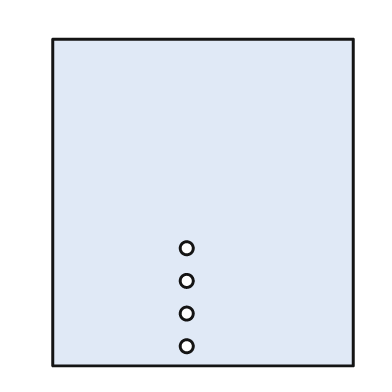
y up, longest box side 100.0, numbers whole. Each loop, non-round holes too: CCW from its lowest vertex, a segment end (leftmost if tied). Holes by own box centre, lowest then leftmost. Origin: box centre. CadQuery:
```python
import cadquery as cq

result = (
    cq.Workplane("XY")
    .moveTo(-46.0, -50.0)
    .lineTo(46.0, -50.0)
    .lineTo(46.0, 50.0)
    .lineTo(-46.0, 50.0)
    .close()
    .moveTo(-5.0, -44.0)
    .circle(2.0)
    .moveTo(-5.0, -34.0)
    .circle(2.0)
    .moveTo(-5.0, -24.0)
    .circle(2.0)
    .moveTo(-5.0, -14.0)
    .circle(2.0)
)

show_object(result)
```